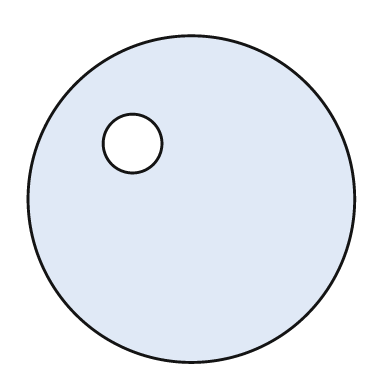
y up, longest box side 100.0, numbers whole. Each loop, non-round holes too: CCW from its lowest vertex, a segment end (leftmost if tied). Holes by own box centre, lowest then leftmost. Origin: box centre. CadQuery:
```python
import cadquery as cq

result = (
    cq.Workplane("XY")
    .moveTo(0.0, 0.0)
    .circle(50.0)
    .moveTo(-18.0, 17.0)
    .circle(9.0)
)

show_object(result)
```